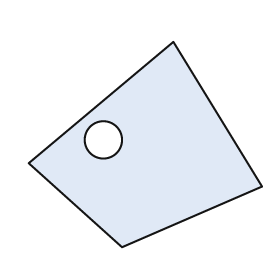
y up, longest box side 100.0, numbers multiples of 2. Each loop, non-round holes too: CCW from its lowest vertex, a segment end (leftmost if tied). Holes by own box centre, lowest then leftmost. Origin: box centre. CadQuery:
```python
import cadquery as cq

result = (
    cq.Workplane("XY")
    .moveTo(-10.0, -44.0)
    .lineTo(50.0, -18.0)
    .lineTo(12.0, 44.0)
    .lineTo(-50.0, -8.0)
    .close()
    .moveTo(-18.0, 2.0)
    .circle(8.0)
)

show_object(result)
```